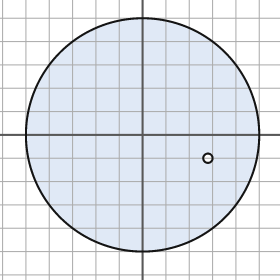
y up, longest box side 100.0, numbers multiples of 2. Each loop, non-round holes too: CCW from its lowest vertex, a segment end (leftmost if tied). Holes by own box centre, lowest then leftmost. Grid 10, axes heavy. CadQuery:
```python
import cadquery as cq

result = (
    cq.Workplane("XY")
    .moveTo(0.0, 0.0)
    .circle(50.0)
    .moveTo(28.0, -10.0)
    .circle(2.0)
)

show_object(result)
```